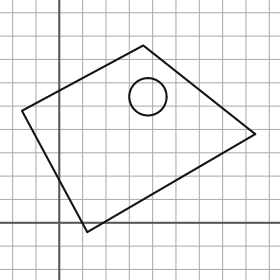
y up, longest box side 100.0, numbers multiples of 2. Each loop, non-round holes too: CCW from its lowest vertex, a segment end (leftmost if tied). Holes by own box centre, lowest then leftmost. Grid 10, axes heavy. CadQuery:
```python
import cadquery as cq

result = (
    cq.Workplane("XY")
    .moveTo(12.0, -4.0)
    .lineTo(84.0, 38.0)
    .lineTo(36.0, 76.0)
    .lineTo(-16.0, 48.0)
    .close()
    .moveTo(38.0, 54.0)
    .circle(8.0)
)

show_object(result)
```